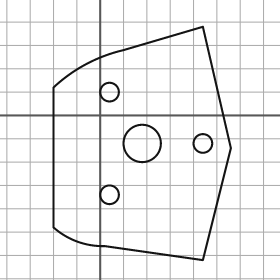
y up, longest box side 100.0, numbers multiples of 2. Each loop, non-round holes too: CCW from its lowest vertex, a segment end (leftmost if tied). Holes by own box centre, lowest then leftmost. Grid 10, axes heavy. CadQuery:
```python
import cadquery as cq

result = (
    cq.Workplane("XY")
    .moveTo(44.0, -62.0)
    .lineTo(56.0, -14.0)
    .lineTo(44.0, 38.0)
    .lineTo(10.0, 28.0)
    .threePointArc((-6.0, 22.0), (-20.0, 12.0))
    .lineTo(-20.0, -48.0)
    .threePointArc((-10.0, -54.0), (2.0, -56.0))
    .close()
    .moveTo(4.0, -34.0)
    .circle(4.0)
    .moveTo(18.0, -12.0)
    .circle(8.0)
    .moveTo(44.0, -12.0)
    .circle(4.0)
    .moveTo(4.0, 10.0)
    .circle(4.0)
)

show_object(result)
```